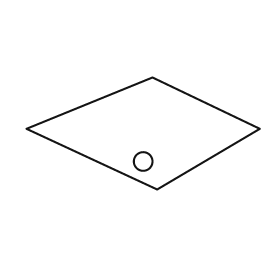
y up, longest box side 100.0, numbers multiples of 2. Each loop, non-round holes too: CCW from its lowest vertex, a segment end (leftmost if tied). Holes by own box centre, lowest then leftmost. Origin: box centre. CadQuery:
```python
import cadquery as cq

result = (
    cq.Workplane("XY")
    .moveTo(6.0, -24.0)
    .lineTo(50.0, 2.0)
    .lineTo(4.0, 24.0)
    .lineTo(-50.0, 2.0)
    .close()
    .moveTo(0.0, -12.0)
    .circle(4.0)
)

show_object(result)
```